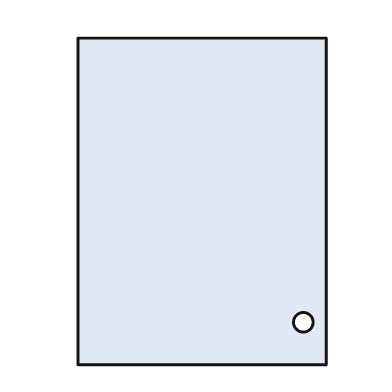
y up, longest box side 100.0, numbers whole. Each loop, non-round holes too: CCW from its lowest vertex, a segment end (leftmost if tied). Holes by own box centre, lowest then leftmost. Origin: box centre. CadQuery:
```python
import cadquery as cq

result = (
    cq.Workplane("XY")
    .moveTo(-38.0, -50.0)
    .lineTo(38.0, -50.0)
    .lineTo(38.0, 50.0)
    .lineTo(-38.0, 50.0)
    .close()
    .moveTo(31.0, -37.0)
    .circle(3.0)
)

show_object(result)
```